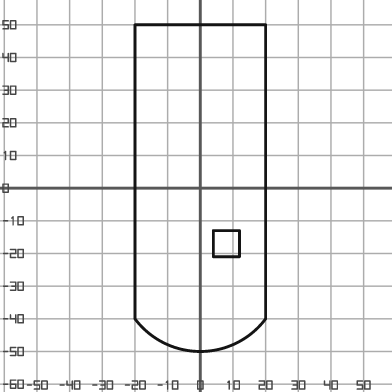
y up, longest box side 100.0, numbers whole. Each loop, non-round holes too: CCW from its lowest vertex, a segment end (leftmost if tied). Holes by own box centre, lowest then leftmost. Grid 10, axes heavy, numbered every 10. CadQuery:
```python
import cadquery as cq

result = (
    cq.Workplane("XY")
    .moveTo(-20.0, -40.0)
    .threePointArc((0.0, -50.0), (20.0, -40.0))
    .lineTo(20.0, 50.0)
    .lineTo(-20.0, 50.0)
    .close()
    .moveTo(4.0, -21.0)
    .lineTo(12.0, -21.0)
    .lineTo(12.0, -13.0)
    .lineTo(4.0, -13.0)
    .close()
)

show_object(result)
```